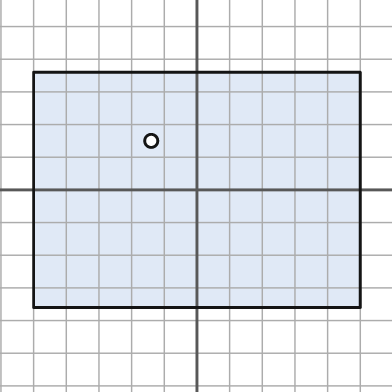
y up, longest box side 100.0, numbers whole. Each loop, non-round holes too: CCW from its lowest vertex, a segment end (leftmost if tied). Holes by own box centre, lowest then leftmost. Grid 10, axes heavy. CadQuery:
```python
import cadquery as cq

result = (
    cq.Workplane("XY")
    .moveTo(-50.0, -36.0)
    .lineTo(50.0, -36.0)
    .lineTo(50.0, 36.0)
    .lineTo(-50.0, 36.0)
    .close()
    .moveTo(-14.0, 15.0)
    .circle(2.0)
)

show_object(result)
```